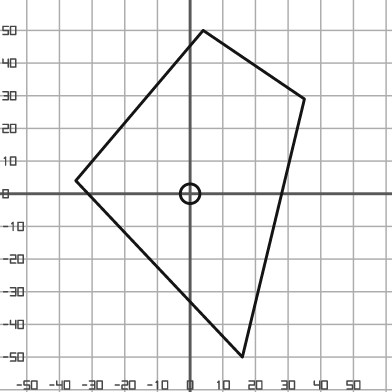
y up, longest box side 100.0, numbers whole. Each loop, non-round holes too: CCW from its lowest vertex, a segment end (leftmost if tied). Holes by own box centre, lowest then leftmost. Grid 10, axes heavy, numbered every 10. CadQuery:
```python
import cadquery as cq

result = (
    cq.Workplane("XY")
    .moveTo(16.0, -50.0)
    .lineTo(35.0, 29.0)
    .lineTo(4.0, 50.0)
    .lineTo(-35.0, 4.0)
    .close()
    .moveTo(0.0, 0.0)
    .circle(3.0)
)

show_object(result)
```